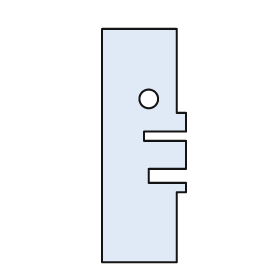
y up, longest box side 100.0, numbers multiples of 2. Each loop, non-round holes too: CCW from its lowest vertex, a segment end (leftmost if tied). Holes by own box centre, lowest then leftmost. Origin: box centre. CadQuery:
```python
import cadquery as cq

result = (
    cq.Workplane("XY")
    .moveTo(-18.0, -50.0)
    .lineTo(14.0, -50.0)
    .lineTo(14.0, -20.0)
    .lineTo(18.0, -20.0)
    .lineTo(18.0, -16.0)
    .lineTo(2.0, -16.0)
    .lineTo(2.0, -10.0)
    .lineTo(18.0, -10.0)
    .lineTo(18.0, 2.0)
    .lineTo(0.0, 2.0)
    .lineTo(0.0, 6.0)
    .lineTo(18.0, 6.0)
    .lineTo(18.0, 14.0)
    .lineTo(14.0, 14.0)
    .lineTo(14.0, 50.0)
    .lineTo(-18.0, 50.0)
    .close()
    .moveTo(2.0, 20.0)
    .circle(4.0)
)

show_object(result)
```